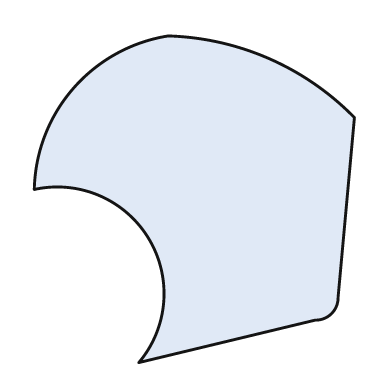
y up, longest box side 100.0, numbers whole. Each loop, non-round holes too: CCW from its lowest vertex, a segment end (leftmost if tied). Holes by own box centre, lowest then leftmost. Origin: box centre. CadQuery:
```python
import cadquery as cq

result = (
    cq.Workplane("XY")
    .moveTo(-17.0, -50.0)
    .lineTo(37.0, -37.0)
    .threePointArc((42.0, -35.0), (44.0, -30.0))
    .lineTo(49.0, 25.0)
    .threePointArc((23.0, 43.0), (-8.0, 50.0))
    .threePointArc((-37.0, 34.0), (-49.0, 3.0))
    .threePointArc((-14.0, -12.0), (-17.0, -50.0))
    .close()
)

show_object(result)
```